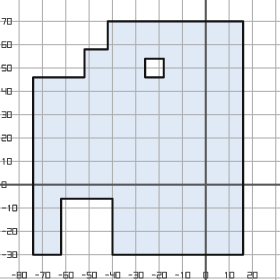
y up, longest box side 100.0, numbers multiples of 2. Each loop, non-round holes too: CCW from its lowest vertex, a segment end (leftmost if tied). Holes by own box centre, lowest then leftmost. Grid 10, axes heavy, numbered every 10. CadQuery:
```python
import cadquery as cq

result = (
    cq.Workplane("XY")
    .moveTo(-74.0, -30.0)
    .lineTo(-62.0, -30.0)
    .lineTo(-62.0, -6.0)
    .lineTo(-40.0, -6.0)
    .lineTo(-40.0, -30.0)
    .lineTo(16.0, -30.0)
    .lineTo(16.0, 70.0)
    .lineTo(-42.0, 70.0)
    .lineTo(-42.0, 58.0)
    .lineTo(-52.0, 58.0)
    .lineTo(-52.0, 46.0)
    .lineTo(-74.0, 46.0)
    .close()
    .moveTo(-26.0, 46.0)
    .lineTo(-18.0, 46.0)
    .lineTo(-18.0, 54.0)
    .lineTo(-26.0, 54.0)
    .close()
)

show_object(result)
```